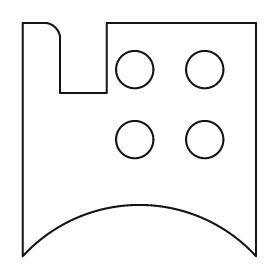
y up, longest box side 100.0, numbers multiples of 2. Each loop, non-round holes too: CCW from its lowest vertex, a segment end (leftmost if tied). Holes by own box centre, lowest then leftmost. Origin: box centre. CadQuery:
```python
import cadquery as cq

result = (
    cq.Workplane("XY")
    .moveTo(-50.0, -50.0)
    .threePointArc((0.0, -28.0), (50.0, -50.0))
    .lineTo(50.0, 50.0)
    .lineTo(-14.0, 50.0)
    .lineTo(-14.0, 20.0)
    .lineTo(-34.0, 20.0)
    .lineTo(-34.0, 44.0)
    .threePointArc((-36.0, 48.0), (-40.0, 50.0))
    .lineTo(-50.0, 50.0)
    .close()
    .moveTo(-2.0, 0.0)
    .circle(8.0)
    .moveTo(28.0, 0.0)
    .circle(8.0)
    .moveTo(-2.0, 30.0)
    .circle(8.0)
    .moveTo(28.0, 30.0)
    .circle(8.0)
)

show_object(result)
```